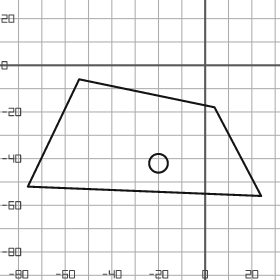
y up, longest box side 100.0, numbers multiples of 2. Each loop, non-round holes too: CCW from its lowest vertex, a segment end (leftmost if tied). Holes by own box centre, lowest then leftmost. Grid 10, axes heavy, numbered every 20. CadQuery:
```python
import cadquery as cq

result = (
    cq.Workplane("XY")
    .moveTo(24.0, -56.0)
    .lineTo(4.0, -18.0)
    .lineTo(-54.0, -6.0)
    .lineTo(-76.0, -52.0)
    .close()
    .moveTo(-20.0, -42.0)
    .circle(4.0)
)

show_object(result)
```